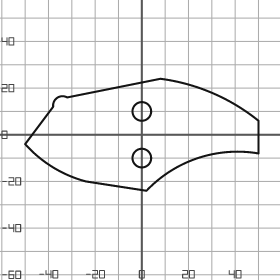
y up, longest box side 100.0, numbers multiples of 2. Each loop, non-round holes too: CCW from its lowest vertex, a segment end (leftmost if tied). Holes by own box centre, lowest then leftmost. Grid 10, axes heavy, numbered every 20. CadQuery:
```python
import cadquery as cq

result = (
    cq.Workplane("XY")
    .moveTo(2.0, -24.0)
    .threePointArc((24.0, -10.0), (50.0, -8.0))
    .lineTo(50.0, 6.0)
    .threePointArc((30.0, 18.0), (8.0, 24.0))
    .lineTo(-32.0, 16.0)
    .threePointArc((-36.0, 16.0), (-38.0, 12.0))
    .lineTo(-50.0, -4.0)
    .threePointArc((-38.0, -14.0), (-24.0, -20.0))
    .close()
    .moveTo(0.0, -10.0)
    .circle(4.0)
    .moveTo(0.0, 10.0)
    .circle(4.0)
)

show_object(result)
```